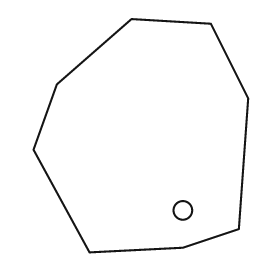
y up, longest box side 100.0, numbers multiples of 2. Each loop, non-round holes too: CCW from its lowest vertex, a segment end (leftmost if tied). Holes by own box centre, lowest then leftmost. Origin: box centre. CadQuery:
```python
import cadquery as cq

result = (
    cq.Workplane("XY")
    .moveTo(-22.0, -50.0)
    .lineTo(18.0, -48.0)
    .lineTo(42.0, -40.0)
    .lineTo(46.0, 16.0)
    .lineTo(30.0, 48.0)
    .lineTo(-4.0, 50.0)
    .lineTo(-36.0, 22.0)
    .lineTo(-46.0, -6.0)
    .close()
    .moveTo(18.0, -32.0)
    .circle(4.0)
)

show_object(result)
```